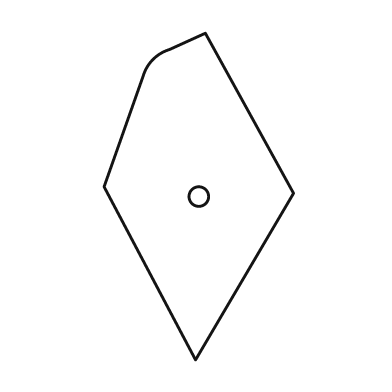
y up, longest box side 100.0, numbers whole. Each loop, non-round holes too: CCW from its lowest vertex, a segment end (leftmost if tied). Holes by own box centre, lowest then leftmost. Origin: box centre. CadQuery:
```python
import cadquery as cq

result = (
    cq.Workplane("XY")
    .moveTo(-1.0, -50.0)
    .lineTo(29.0, 1.0)
    .lineTo(2.0, 50.0)
    .lineTo(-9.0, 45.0)
    .threePointArc((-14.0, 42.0), (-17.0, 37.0))
    .lineTo(-29.0, 3.0)
    .close()
    .moveTo(0.0, 0.0)
    .circle(3.0)
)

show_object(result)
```